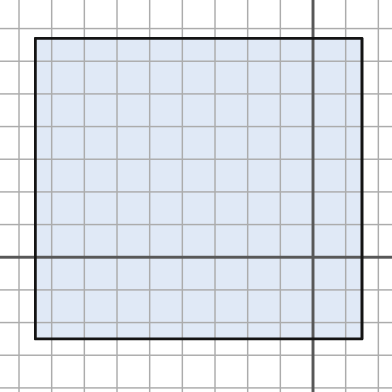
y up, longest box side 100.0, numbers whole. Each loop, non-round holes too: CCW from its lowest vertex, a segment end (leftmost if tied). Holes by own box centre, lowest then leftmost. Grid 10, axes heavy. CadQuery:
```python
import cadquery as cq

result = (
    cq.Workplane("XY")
    .moveTo(-85.0, -25.0)
    .lineTo(15.0, -25.0)
    .lineTo(15.0, 67.0)
    .lineTo(-85.0, 67.0)
    .close()
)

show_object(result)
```